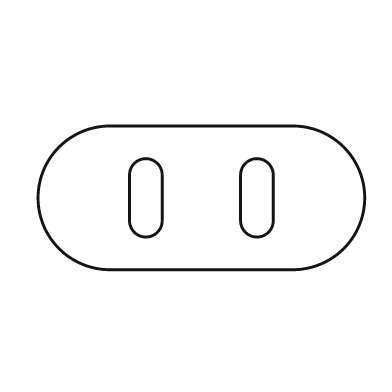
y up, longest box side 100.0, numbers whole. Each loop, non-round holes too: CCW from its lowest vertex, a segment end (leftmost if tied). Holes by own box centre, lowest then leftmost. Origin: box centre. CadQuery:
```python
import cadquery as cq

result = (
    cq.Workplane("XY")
    .moveTo(-28.0, -22.0)
    .lineTo(28.0, -22.0)
    .threePointArc((50.0, 0.0), (28.0, 22.0))
    .lineTo(-28.0, 22.0)
    .threePointArc((-50.0, 0.0), (-28.0, -22.0))
    .close()
    .moveTo(-22.0, -7.0)
    .threePointArc((-17.0, -12.0), (-12.0, -7.0))
    .lineTo(-12.0, 7.0)
    .threePointArc((-17.0, 12.0), (-22.0, 7.0))
    .close()
    .moveTo(12.0, -7.0)
    .threePointArc((17.0, -12.0), (22.0, -7.0))
    .lineTo(22.0, 7.0)
    .threePointArc((17.0, 12.0), (12.0, 7.0))
    .close()
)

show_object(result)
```